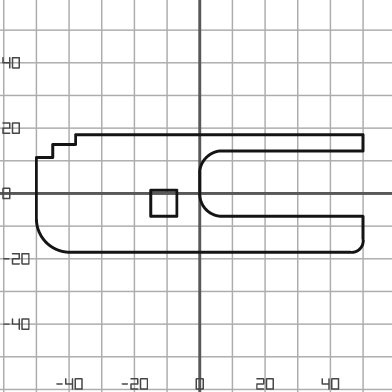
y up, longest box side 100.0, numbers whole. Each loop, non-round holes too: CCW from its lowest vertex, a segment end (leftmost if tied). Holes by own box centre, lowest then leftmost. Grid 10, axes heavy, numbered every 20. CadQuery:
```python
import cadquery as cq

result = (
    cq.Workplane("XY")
    .moveTo(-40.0, -18.0)
    .lineTo(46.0, -18.0)
    .threePointArc((49.0, -17.0), (50.0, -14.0))
    .lineTo(50.0, -7.0)
    .lineTo(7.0, -7.0)
    .threePointArc((2.0, -5.0), (0.0, 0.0))
    .lineTo(0.0, 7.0)
    .threePointArc((2.0, 11.0), (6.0, 13.0))
    .lineTo(50.0, 13.0)
    .lineTo(50.0, 18.0)
    .lineTo(-38.0, 18.0)
    .lineTo(-38.0, 15.0)
    .lineTo(-45.0, 15.0)
    .lineTo(-45.0, 11.0)
    .lineTo(-50.0, 11.0)
    .lineTo(-50.0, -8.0)
    .threePointArc((-47.0, -15.0), (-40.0, -18.0))
    .close()
    .moveTo(-15.0, -7.0)
    .lineTo(-7.0, -7.0)
    .lineTo(-7.0, 1.0)
    .lineTo(-15.0, 1.0)
    .close()
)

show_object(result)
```